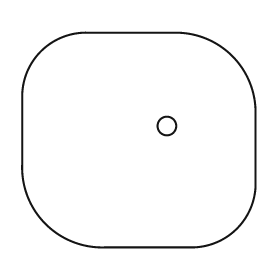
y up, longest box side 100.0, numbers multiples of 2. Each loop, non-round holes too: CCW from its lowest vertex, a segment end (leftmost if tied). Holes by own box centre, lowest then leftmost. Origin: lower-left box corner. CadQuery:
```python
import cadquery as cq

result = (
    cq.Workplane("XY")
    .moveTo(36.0, 0.0)
    .lineTo(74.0, 0.0)
    .threePointArc((92.0, 8.0), (100.0, 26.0))
    .lineTo(100.0, 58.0)
    .threePointArc((90.0, 82.0), (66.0, 92.0))
    .lineTo(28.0, 92.0)
    .threePointArc((8.0, 84.0), (0.0, 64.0))
    .lineTo(0.0, 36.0)
    .threePointArc((10.0, 10.0), (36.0, 0.0))
    .close()
    .moveTo(62.0, 52.0)
    .circle(4.0)
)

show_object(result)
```